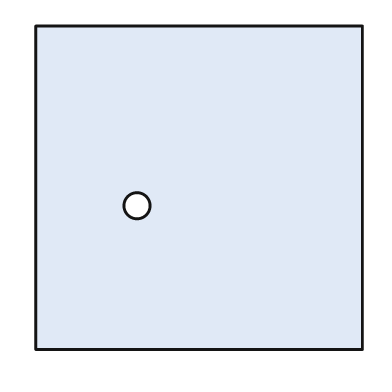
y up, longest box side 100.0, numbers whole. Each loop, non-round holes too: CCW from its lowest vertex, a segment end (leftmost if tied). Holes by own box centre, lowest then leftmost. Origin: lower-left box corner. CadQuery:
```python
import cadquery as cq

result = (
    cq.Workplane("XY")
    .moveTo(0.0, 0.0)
    .lineTo(100.0, 0.0)
    .lineTo(100.0, 99.0)
    .lineTo(0.0, 99.0)
    .close()
    .moveTo(31.0, 44.0)
    .circle(4.0)
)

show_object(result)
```